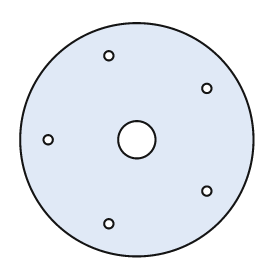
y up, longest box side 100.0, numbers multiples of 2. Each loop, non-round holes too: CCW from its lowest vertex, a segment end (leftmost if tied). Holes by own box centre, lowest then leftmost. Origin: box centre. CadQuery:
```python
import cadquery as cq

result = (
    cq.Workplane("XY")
    .moveTo(0.0, 0.0)
    .circle(50.0)
    .moveTo(-12.0, -36.0)
    .circle(2.0)
    .moveTo(30.0, -22.0)
    .circle(2.0)
    .moveTo(-38.0, 0.0)
    .circle(2.0)
    .moveTo(0.0, 0.0)
    .circle(8.0)
    .moveTo(30.0, 22.0)
    .circle(2.0)
    .moveTo(-12.0, 36.0)
    .circle(2.0)
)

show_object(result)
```